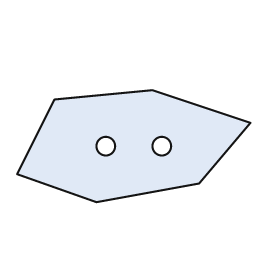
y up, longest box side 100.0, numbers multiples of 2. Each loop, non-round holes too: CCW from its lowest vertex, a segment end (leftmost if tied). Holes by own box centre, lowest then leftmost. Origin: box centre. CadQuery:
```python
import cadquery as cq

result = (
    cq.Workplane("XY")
    .moveTo(-16.0, -24.0)
    .lineTo(28.0, -16.0)
    .lineTo(50.0, 10.0)
    .lineTo(8.0, 24.0)
    .lineTo(-34.0, 20.0)
    .lineTo(-50.0, -12.0)
    .close()
    .moveTo(-12.0, 0.0)
    .circle(4.0)
    .moveTo(12.0, 0.0)
    .circle(4.0)
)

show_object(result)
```